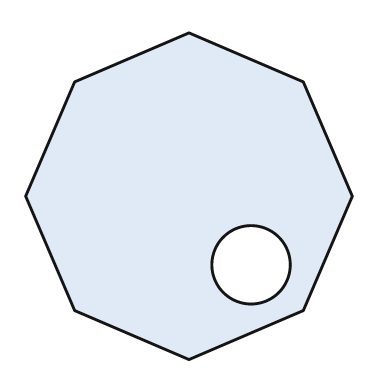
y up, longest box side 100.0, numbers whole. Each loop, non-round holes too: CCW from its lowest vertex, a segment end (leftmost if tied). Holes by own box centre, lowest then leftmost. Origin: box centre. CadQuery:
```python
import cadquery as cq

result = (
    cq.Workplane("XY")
    .moveTo(0.0, -50.0)
    .lineTo(35.0, -35.0)
    .lineTo(50.0, 0.0)
    .lineTo(35.0, 35.0)
    .lineTo(0.0, 50.0)
    .lineTo(-35.0, 35.0)
    .lineTo(-50.0, 0.0)
    .lineTo(-35.0, -35.0)
    .close()
    .moveTo(19.0, -21.0)
    .circle(12.0)
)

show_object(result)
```